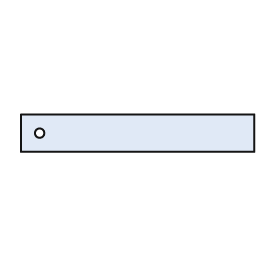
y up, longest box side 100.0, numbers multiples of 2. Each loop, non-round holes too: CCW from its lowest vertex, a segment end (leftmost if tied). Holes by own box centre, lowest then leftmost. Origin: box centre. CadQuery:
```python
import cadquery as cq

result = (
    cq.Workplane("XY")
    .moveTo(-50.0, -8.0)
    .lineTo(50.0, -8.0)
    .lineTo(50.0, 8.0)
    .lineTo(-50.0, 8.0)
    .close()
    .moveTo(-42.0, 0.0)
    .circle(2.0)
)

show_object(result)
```